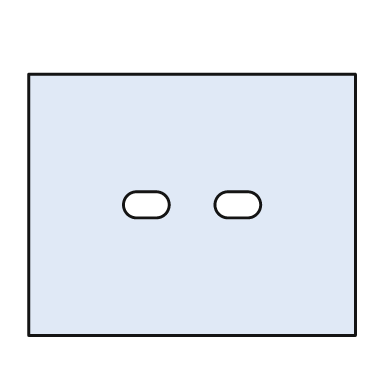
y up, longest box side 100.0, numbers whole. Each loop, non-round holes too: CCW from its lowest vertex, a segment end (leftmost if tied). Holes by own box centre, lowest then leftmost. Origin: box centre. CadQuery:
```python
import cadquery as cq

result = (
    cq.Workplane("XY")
    .moveTo(-50.0, -40.0)
    .lineTo(50.0, -40.0)
    .lineTo(50.0, 40.0)
    .lineTo(-50.0, 40.0)
    .close()
    .moveTo(-17.0, -4.0)
    .lineTo(-11.0, -4.0)
    .threePointArc((-7.0, 0.0), (-11.0, 4.0))
    .lineTo(-17.0, 4.0)
    .threePointArc((-21.0, 0.0), (-17.0, -4.0))
    .close()
    .moveTo(11.0, -4.0)
    .lineTo(17.0, -4.0)
    .threePointArc((21.0, 0.0), (17.0, 4.0))
    .lineTo(11.0, 4.0)
    .threePointArc((7.0, 0.0), (11.0, -4.0))
    .close()
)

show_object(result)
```